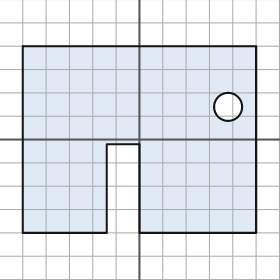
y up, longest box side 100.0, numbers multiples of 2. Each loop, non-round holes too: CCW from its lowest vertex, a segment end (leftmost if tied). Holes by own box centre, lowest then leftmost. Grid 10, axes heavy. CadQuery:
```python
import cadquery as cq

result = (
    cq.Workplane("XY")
    .moveTo(-50.0, -40.0)
    .lineTo(-14.0, -40.0)
    .lineTo(-14.0, -2.0)
    .lineTo(0.0, -2.0)
    .lineTo(0.0, -40.0)
    .lineTo(50.0, -40.0)
    .lineTo(50.0, 40.0)
    .lineTo(-50.0, 40.0)
    .close()
    .moveTo(38.0, 14.0)
    .circle(6.0)
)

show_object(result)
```